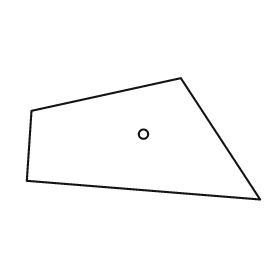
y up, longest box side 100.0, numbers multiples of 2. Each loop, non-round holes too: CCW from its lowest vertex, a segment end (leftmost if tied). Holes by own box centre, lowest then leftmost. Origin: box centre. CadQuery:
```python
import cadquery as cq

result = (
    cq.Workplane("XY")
    .moveTo(50.0, -26.0)
    .lineTo(16.0, 26.0)
    .lineTo(-48.0, 12.0)
    .lineTo(-50.0, -18.0)
    .close()
    .moveTo(0.0, 2.0)
    .circle(2.0)
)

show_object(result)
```